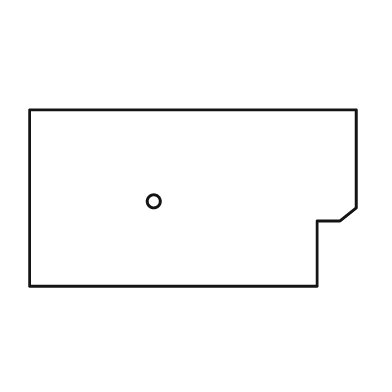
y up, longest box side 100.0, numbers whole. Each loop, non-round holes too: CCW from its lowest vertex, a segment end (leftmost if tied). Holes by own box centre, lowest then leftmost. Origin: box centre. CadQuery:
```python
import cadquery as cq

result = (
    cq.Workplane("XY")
    .moveTo(-50.0, -27.0)
    .lineTo(38.0, -27.0)
    .lineTo(38.0, -7.0)
    .lineTo(45.0, -7.0)
    .lineTo(50.0, -3.0)
    .lineTo(50.0, 27.0)
    .lineTo(-50.0, 27.0)
    .close()
    .moveTo(-12.0, -1.0)
    .circle(2.0)
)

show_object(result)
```